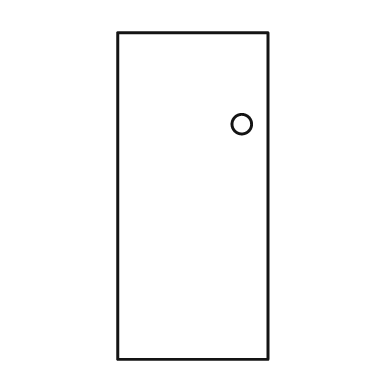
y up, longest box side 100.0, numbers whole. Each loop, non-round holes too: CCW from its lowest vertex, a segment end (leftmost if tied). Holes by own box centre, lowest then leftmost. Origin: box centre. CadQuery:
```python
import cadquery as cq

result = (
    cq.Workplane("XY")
    .moveTo(-23.0, -50.0)
    .lineTo(23.0, -50.0)
    .lineTo(23.0, 50.0)
    .lineTo(-23.0, 50.0)
    .close()
    .moveTo(15.0, 22.0)
    .circle(3.0)
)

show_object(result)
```